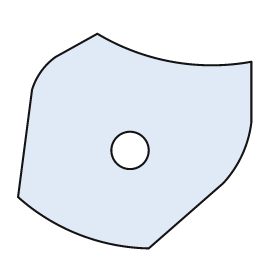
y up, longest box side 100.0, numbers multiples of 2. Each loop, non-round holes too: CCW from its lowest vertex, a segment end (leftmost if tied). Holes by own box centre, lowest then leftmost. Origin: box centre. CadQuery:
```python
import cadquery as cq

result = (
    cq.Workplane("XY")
    .moveTo(6.0, -46.0)
    .lineTo(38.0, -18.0)
    .threePointArc((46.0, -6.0), (50.0, 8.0))
    .lineTo(50.0, 34.0)
    .threePointArc((16.0, 34.0), (-16.0, 46.0))
    .lineTo(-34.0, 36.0)
    .threePointArc((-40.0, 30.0), (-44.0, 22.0))
    .lineTo(-50.0, -24.0)
    .threePointArc((-24.0, -40.0), (6.0, -46.0))
    .close()
    .moveTo(-2.0, -4.0)
    .circle(8.0)
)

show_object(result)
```